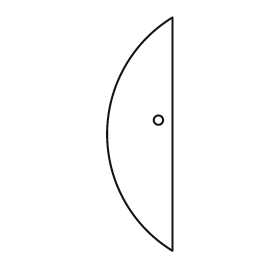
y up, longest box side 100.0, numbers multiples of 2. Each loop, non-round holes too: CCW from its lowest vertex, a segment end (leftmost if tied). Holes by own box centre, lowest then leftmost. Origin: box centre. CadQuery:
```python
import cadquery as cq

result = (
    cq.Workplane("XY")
    .moveTo(14.0, -50.0)
    .lineTo(14.0, 50.0)
    .threePointArc((-14.0, 0.0), (14.0, -50.0))
    .close()
    .moveTo(8.0, 6.0)
    .circle(2.0)
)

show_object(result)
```